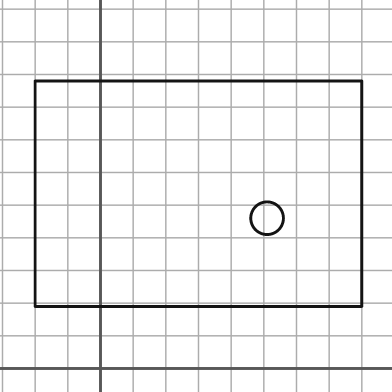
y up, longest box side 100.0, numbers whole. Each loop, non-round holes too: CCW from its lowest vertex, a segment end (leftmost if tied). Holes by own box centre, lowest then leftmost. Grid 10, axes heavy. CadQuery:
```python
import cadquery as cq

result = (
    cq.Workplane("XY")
    .moveTo(-20.0, 19.0)
    .lineTo(80.0, 19.0)
    .lineTo(80.0, 88.0)
    .lineTo(-20.0, 88.0)
    .close()
    .moveTo(51.0, 46.0)
    .circle(5.0)
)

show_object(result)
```